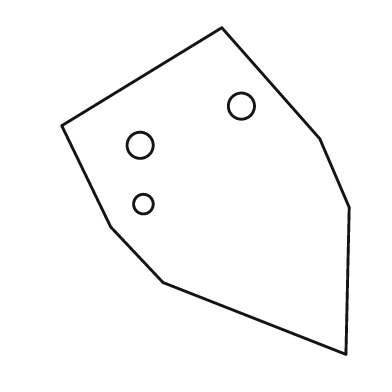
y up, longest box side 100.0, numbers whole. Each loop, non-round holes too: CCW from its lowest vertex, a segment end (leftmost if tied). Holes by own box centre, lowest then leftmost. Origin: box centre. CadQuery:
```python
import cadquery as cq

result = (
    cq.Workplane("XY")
    .moveTo(43.0, -50.0)
    .lineTo(44.0, -5.0)
    .lineTo(35.0, 16.0)
    .lineTo(5.0, 50.0)
    .lineTo(-44.0, 20.0)
    .lineTo(-29.0, -11.0)
    .lineTo(-13.0, -28.0)
    .close()
    .moveTo(-19.0, -4.0)
    .circle(3.0)
    .moveTo(-20.0, 14.0)
    .circle(4.0)
    .moveTo(11.0, 26.0)
    .circle(4.0)
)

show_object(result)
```